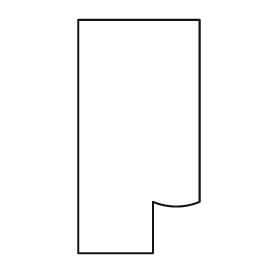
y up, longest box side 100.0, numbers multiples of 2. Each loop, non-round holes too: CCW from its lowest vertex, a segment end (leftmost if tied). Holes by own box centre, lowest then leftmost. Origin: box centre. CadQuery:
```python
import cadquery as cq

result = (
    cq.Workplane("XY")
    .moveTo(-26.0, -50.0)
    .lineTo(6.0, -50.0)
    .lineTo(6.0, -28.0)
    .threePointArc((16.0, -30.0), (26.0, -28.0))
    .lineTo(26.0, 50.0)
    .lineTo(-26.0, 50.0)
    .close()
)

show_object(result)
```